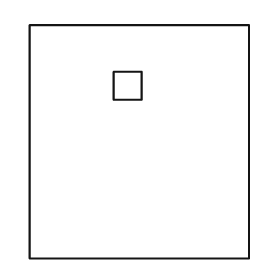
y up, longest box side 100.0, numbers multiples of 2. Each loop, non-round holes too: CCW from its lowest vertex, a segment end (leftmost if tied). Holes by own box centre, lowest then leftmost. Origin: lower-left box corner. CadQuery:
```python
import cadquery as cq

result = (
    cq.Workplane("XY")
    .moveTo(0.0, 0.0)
    .lineTo(94.0, 0.0)
    .lineTo(94.0, 100.0)
    .lineTo(0.0, 100.0)
    .close()
    .moveTo(36.0, 68.0)
    .lineTo(48.0, 68.0)
    .lineTo(48.0, 80.0)
    .lineTo(36.0, 80.0)
    .close()
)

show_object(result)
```